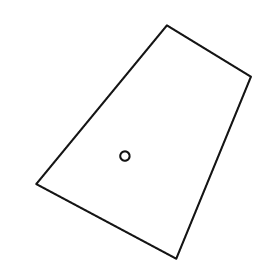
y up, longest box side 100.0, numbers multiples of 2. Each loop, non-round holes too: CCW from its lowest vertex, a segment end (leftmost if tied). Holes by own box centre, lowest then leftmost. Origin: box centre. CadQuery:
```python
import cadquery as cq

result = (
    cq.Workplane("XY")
    .moveTo(14.0, -50.0)
    .lineTo(46.0, 28.0)
    .lineTo(10.0, 50.0)
    .lineTo(-46.0, -18.0)
    .close()
    .moveTo(-8.0, -6.0)
    .circle(2.0)
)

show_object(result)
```